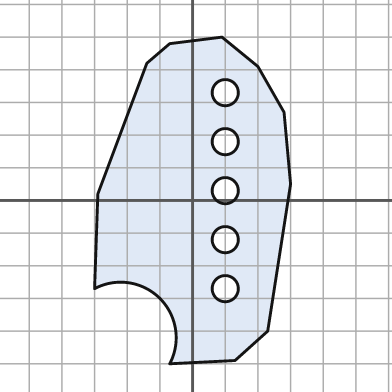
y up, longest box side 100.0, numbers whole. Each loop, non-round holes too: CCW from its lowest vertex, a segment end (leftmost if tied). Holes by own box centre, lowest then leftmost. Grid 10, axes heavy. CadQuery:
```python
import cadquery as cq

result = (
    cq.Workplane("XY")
    .moveTo(-7.0, -50.0)
    .lineTo(13.0, -49.0)
    .lineTo(23.0, -40.0)
    .lineTo(30.0, 5.0)
    .lineTo(28.0, 27.0)
    .lineTo(20.0, 41.0)
    .lineTo(9.0, 50.0)
    .lineTo(-7.0, 48.0)
    .lineTo(-14.0, 42.0)
    .lineTo(-29.0, 2.0)
    .lineTo(-30.0, -27.0)
    .threePointArc((-10.0, -30.0), (-7.0, -50.0))
    .close()
    .moveTo(10.0, -27.0)
    .circle(4.0)
    .moveTo(10.0, -12.0)
    .circle(4.0)
    .moveTo(10.0, 3.0)
    .circle(4.0)
    .moveTo(10.0, 18.0)
    .circle(4.0)
    .moveTo(10.0, 33.0)
    .circle(4.0)
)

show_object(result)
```